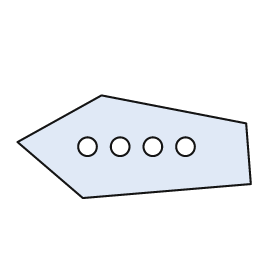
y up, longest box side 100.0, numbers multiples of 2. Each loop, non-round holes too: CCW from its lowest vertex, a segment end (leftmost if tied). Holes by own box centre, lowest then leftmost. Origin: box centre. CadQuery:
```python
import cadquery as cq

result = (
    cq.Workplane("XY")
    .moveTo(-22.0, -22.0)
    .lineTo(50.0, -16.0)
    .lineTo(48.0, 10.0)
    .lineTo(-14.0, 22.0)
    .lineTo(-50.0, 2.0)
    .close()
    .moveTo(-20.0, 0.0)
    .circle(4.0)
    .moveTo(-6.0, 0.0)
    .circle(4.0)
    .moveTo(8.0, 0.0)
    .circle(4.0)
    .moveTo(22.0, 0.0)
    .circle(4.0)
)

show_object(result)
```